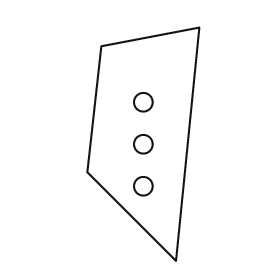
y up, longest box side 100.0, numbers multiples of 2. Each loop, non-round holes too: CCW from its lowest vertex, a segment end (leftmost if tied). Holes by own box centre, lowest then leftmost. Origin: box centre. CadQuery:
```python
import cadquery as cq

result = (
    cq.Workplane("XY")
    .moveTo(14.0, -50.0)
    .lineTo(24.0, 50.0)
    .lineTo(-18.0, 42.0)
    .lineTo(-24.0, -12.0)
    .close()
    .moveTo(0.0, -18.0)
    .circle(4.0)
    .moveTo(0.0, 0.0)
    .circle(4.0)
    .moveTo(0.0, 18.0)
    .circle(4.0)
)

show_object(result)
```